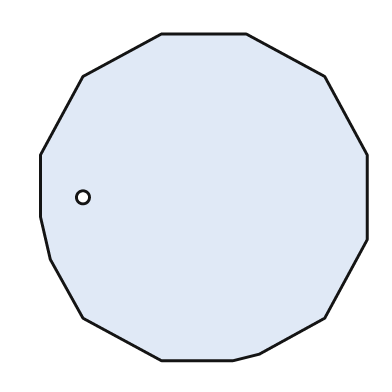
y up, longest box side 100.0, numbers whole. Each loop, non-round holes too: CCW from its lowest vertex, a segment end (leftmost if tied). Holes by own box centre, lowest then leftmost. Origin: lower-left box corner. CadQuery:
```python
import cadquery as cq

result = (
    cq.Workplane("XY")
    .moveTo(37.0, 0.0)
    .lineTo(59.0, 0.0)
    .lineTo(67.0, 2.0)
    .lineTo(87.0, 13.0)
    .lineTo(100.0, 37.0)
    .lineTo(100.0, 63.0)
    .lineTo(87.0, 87.0)
    .lineTo(63.0, 100.0)
    .lineTo(37.0, 100.0)
    .lineTo(13.0, 87.0)
    .lineTo(0.0, 63.0)
    .lineTo(0.0, 44.0)
    .lineTo(3.0, 31.0)
    .lineTo(13.0, 13.0)
    .close()
    .moveTo(13.0, 50.0)
    .circle(2.0)
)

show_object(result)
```